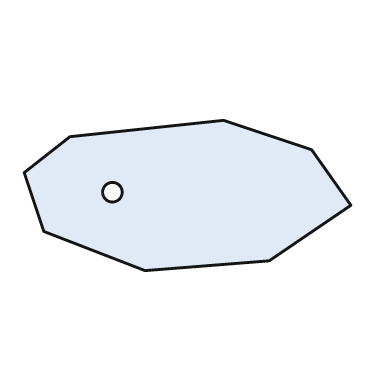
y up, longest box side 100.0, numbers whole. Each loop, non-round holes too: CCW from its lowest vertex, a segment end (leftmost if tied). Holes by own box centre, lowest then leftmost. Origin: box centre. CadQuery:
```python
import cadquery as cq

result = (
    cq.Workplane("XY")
    .moveTo(-13.0, -23.0)
    .lineTo(25.0, -20.0)
    .lineTo(50.0, -3.0)
    .lineTo(38.0, 14.0)
    .lineTo(11.0, 23.0)
    .lineTo(-36.0, 18.0)
    .lineTo(-50.0, 7.0)
    .lineTo(-44.0, -11.0)
    .close()
    .moveTo(-23.0, 1.0)
    .circle(3.0)
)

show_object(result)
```